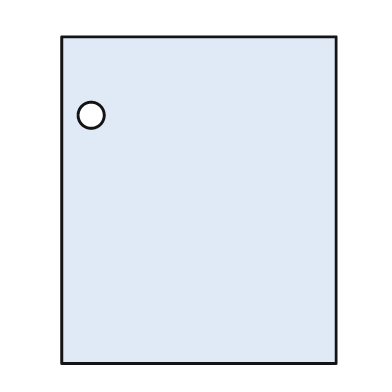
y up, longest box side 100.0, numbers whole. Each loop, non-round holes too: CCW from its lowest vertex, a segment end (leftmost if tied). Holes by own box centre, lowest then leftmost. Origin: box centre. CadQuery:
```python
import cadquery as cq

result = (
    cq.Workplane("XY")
    .moveTo(-42.0, -50.0)
    .lineTo(42.0, -50.0)
    .lineTo(42.0, 50.0)
    .lineTo(-42.0, 50.0)
    .close()
    .moveTo(-33.0, 26.0)
    .circle(4.0)
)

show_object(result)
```